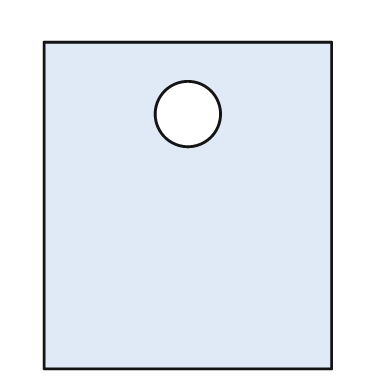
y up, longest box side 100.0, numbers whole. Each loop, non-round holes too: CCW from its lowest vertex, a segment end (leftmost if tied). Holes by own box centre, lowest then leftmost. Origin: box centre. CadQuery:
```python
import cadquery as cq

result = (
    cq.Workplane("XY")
    .moveTo(-44.0, -50.0)
    .lineTo(44.0, -50.0)
    .lineTo(44.0, 50.0)
    .lineTo(-44.0, 50.0)
    .close()
    .moveTo(0.0, 28.0)
    .circle(10.0)
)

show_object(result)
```